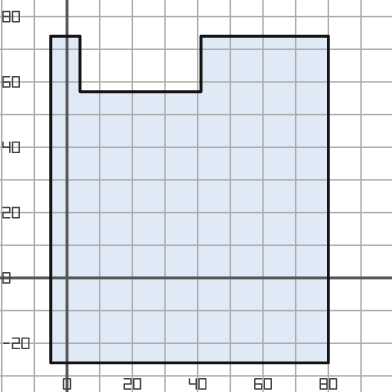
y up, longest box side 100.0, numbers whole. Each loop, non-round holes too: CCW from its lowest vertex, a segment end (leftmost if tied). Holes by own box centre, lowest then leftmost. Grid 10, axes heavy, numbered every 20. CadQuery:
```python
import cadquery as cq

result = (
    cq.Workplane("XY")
    .moveTo(-5.0, -26.0)
    .lineTo(80.0, -26.0)
    .lineTo(80.0, 74.0)
    .lineTo(41.0, 74.0)
    .lineTo(41.0, 57.0)
    .lineTo(4.0, 57.0)
    .lineTo(4.0, 74.0)
    .lineTo(-5.0, 74.0)
    .close()
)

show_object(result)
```